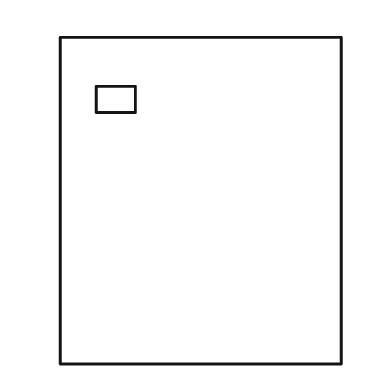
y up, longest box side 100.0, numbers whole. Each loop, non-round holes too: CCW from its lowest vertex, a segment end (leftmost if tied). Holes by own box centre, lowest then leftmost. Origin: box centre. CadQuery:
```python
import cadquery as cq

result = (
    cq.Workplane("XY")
    .moveTo(-43.0, -50.0)
    .lineTo(43.0, -50.0)
    .lineTo(43.0, 50.0)
    .lineTo(-43.0, 50.0)
    .close()
    .moveTo(-32.0, 27.0)
    .lineTo(-20.0, 27.0)
    .lineTo(-20.0, 35.0)
    .lineTo(-32.0, 35.0)
    .close()
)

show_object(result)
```